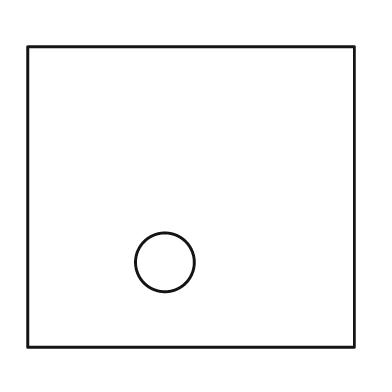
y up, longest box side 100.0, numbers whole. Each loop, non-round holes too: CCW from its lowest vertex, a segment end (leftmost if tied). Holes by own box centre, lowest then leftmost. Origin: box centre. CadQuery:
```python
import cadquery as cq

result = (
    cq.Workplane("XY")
    .moveTo(-50.0, -46.0)
    .lineTo(50.0, -46.0)
    .lineTo(50.0, 46.0)
    .lineTo(-50.0, 46.0)
    .close()
    .moveTo(-8.0, -20.0)
    .circle(9.0)
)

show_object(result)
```